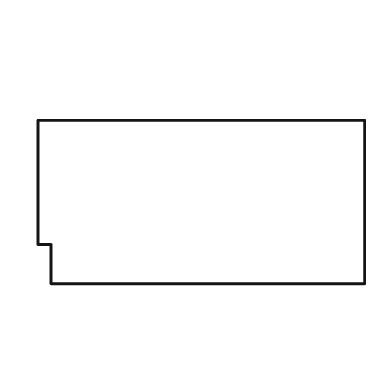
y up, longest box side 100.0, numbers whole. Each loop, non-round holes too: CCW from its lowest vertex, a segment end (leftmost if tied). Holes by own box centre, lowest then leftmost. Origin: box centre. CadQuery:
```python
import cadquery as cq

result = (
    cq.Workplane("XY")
    .moveTo(-46.0, -25.0)
    .lineTo(50.0, -25.0)
    .lineTo(50.0, 25.0)
    .lineTo(-50.0, 25.0)
    .lineTo(-50.0, -13.0)
    .lineTo(-46.0, -13.0)
    .close()
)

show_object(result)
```